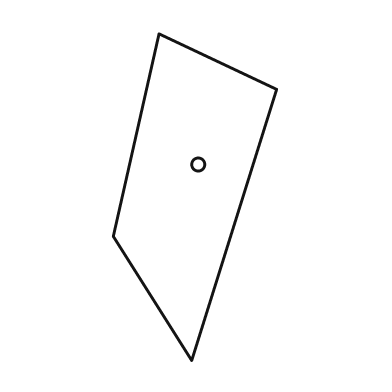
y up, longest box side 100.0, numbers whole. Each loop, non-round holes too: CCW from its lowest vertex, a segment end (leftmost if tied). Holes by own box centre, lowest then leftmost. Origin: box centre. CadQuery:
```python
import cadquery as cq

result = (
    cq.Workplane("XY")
    .moveTo(-1.0, -50.0)
    .lineTo(25.0, 33.0)
    .lineTo(-11.0, 50.0)
    .lineTo(-25.0, -12.0)
    .close()
    .moveTo(1.0, 10.0)
    .circle(2.0)
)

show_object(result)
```